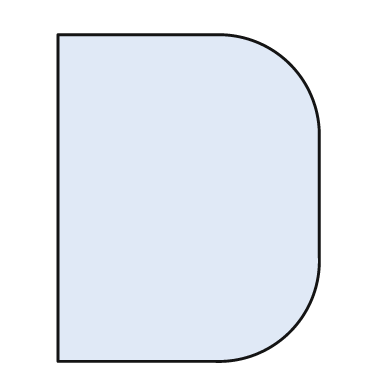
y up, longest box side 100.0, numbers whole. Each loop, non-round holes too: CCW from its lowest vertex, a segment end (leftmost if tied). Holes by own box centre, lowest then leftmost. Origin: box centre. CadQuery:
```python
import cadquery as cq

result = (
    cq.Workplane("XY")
    .moveTo(-40.0, -50.0)
    .lineTo(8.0, -50.0)
    .threePointArc((31.0, -41.0), (40.0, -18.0))
    .lineTo(40.0, 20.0)
    .threePointArc((31.0, 41.0), (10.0, 50.0))
    .lineTo(-40.0, 50.0)
    .close()
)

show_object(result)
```